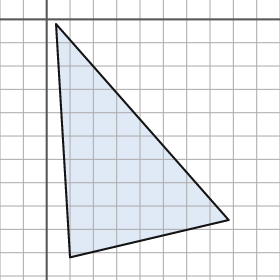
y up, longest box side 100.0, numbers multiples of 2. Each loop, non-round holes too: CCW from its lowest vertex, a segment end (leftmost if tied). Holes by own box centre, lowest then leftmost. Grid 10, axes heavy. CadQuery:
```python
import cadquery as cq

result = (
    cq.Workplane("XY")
    .moveTo(10.0, -102.0)
    .lineTo(78.0, -86.0)
    .lineTo(4.0, -2.0)
    .close()
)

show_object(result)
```